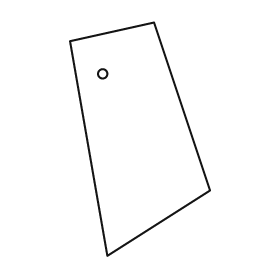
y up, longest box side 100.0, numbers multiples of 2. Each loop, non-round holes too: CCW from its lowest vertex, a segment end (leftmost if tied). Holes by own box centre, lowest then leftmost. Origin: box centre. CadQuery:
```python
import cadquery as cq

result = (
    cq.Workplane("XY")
    .moveTo(-14.0, -50.0)
    .lineTo(30.0, -22.0)
    .lineTo(6.0, 50.0)
    .lineTo(-30.0, 42.0)
    .close()
    .moveTo(-16.0, 28.0)
    .circle(2.0)
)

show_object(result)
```